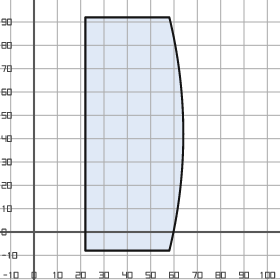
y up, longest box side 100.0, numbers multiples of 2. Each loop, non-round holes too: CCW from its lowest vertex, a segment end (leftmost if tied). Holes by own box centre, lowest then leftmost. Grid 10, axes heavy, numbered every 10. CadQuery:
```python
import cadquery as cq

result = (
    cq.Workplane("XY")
    .moveTo(22.0, -8.0)
    .lineTo(58.0, -8.0)
    .threePointArc((64.0, 42.0), (58.0, 92.0))
    .lineTo(22.0, 92.0)
    .close()
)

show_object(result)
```